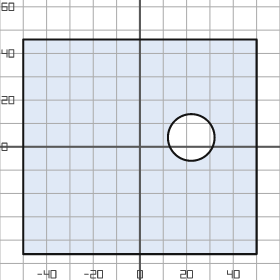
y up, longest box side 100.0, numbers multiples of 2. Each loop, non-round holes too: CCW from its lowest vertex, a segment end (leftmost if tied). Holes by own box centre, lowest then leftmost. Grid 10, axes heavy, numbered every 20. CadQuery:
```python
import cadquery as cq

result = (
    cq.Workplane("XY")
    .moveTo(-50.0, -46.0)
    .lineTo(50.0, -46.0)
    .lineTo(50.0, 46.0)
    .lineTo(-50.0, 46.0)
    .close()
    .moveTo(22.0, 4.0)
    .circle(10.0)
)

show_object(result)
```